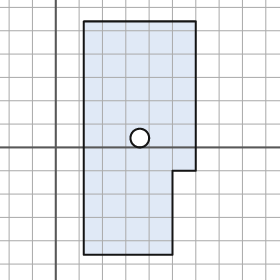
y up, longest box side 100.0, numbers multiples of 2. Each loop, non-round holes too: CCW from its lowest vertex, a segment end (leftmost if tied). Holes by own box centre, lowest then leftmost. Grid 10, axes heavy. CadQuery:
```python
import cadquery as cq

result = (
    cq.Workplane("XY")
    .moveTo(12.0, -46.0)
    .lineTo(50.0, -46.0)
    .lineTo(50.0, -10.0)
    .lineTo(60.0, -10.0)
    .lineTo(60.0, 54.0)
    .lineTo(12.0, 54.0)
    .close()
    .moveTo(36.0, 4.0)
    .circle(4.0)
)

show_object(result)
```